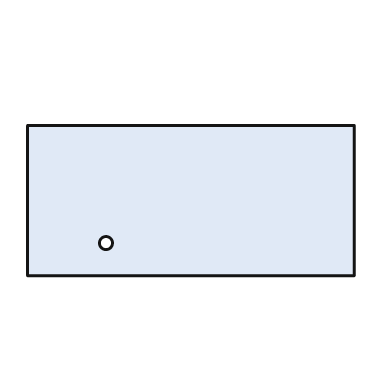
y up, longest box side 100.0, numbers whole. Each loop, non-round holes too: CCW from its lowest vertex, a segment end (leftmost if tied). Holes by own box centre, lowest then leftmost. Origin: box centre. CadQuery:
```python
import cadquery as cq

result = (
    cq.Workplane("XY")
    .moveTo(-50.0, -23.0)
    .lineTo(50.0, -23.0)
    .lineTo(50.0, 23.0)
    .lineTo(-50.0, 23.0)
    .close()
    .moveTo(-26.0, -13.0)
    .circle(2.0)
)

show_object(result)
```